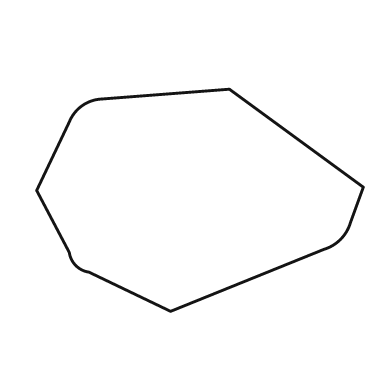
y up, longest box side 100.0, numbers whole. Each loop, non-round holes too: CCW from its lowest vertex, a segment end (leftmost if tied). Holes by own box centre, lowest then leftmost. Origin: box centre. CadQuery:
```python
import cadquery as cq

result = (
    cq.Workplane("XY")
    .moveTo(-9.0, -34.0)
    .lineTo(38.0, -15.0)
    .threePointArc((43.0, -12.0), (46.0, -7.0))
    .lineTo(50.0, 4.0)
    .lineTo(9.0, 34.0)
    .lineTo(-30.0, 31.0)
    .threePointArc((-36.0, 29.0), (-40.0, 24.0))
    .lineTo(-50.0, 3.0)
    .lineTo(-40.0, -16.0)
    .threePointArc((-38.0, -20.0), (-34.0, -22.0))
    .close()
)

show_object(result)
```